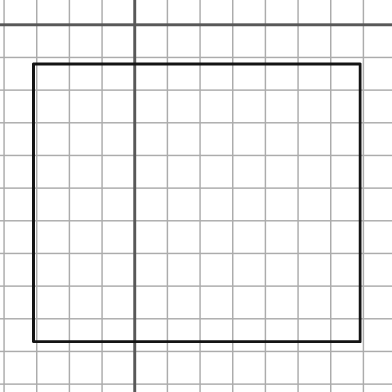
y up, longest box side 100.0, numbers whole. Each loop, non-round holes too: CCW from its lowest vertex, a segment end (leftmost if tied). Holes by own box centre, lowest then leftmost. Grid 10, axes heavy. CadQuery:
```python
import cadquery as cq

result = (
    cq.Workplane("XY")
    .moveTo(-31.0, -97.0)
    .lineTo(69.0, -97.0)
    .lineTo(69.0, -12.0)
    .lineTo(-31.0, -12.0)
    .close()
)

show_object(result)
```